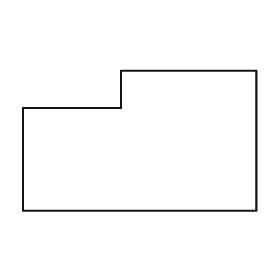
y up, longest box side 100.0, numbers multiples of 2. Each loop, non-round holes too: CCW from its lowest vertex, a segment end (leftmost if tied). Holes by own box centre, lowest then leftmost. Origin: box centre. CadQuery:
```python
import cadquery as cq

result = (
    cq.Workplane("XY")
    .moveTo(-50.0, -30.0)
    .lineTo(50.0, -30.0)
    .lineTo(50.0, 30.0)
    .lineTo(-8.0, 30.0)
    .lineTo(-8.0, 14.0)
    .lineTo(-50.0, 14.0)
    .close()
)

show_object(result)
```